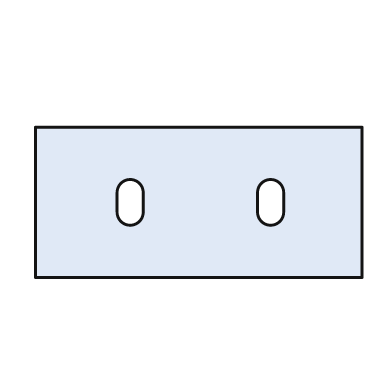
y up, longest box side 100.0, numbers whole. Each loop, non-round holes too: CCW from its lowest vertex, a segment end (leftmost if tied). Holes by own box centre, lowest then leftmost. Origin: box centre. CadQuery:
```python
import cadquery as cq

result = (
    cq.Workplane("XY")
    .moveTo(-50.0, -23.0)
    .lineTo(50.0, -23.0)
    .lineTo(50.0, 23.0)
    .lineTo(-50.0, 23.0)
    .close()
    .moveTo(-25.0, -3.0)
    .threePointArc((-21.0, -7.0), (-17.0, -3.0))
    .lineTo(-17.0, 3.0)
    .threePointArc((-21.0, 7.0), (-25.0, 3.0))
    .close()
    .moveTo(18.0, -3.0)
    .threePointArc((22.0, -7.0), (26.0, -3.0))
    .lineTo(26.0, 3.0)
    .threePointArc((22.0, 7.0), (18.0, 3.0))
    .close()
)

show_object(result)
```